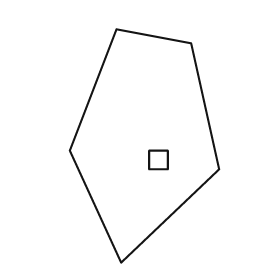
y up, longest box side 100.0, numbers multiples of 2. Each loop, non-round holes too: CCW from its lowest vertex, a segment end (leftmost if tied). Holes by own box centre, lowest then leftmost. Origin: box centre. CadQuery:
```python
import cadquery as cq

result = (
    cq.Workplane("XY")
    .moveTo(-10.0, -50.0)
    .lineTo(32.0, -10.0)
    .lineTo(20.0, 44.0)
    .lineTo(-12.0, 50.0)
    .lineTo(-32.0, -2.0)
    .close()
    .moveTo(2.0, -10.0)
    .lineTo(10.0, -10.0)
    .lineTo(10.0, -2.0)
    .lineTo(2.0, -2.0)
    .close()
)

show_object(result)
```